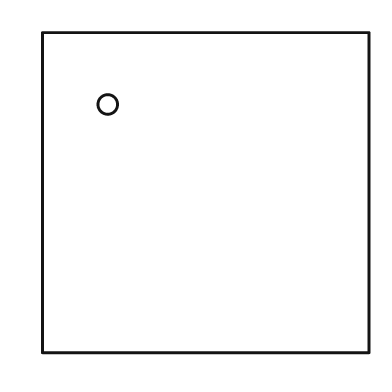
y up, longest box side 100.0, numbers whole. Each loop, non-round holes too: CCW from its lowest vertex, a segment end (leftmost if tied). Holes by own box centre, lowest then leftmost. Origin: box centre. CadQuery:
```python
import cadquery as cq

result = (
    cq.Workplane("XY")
    .moveTo(-50.0, -49.0)
    .lineTo(50.0, -49.0)
    .lineTo(50.0, 49.0)
    .lineTo(-50.0, 49.0)
    .close()
    .moveTo(-30.0, 27.0)
    .circle(3.0)
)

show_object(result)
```